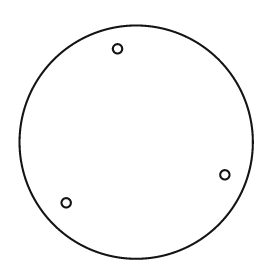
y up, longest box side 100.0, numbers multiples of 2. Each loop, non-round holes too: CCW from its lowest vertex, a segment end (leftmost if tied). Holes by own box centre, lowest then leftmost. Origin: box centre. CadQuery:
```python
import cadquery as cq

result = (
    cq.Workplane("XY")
    .moveTo(0.0, 0.0)
    .circle(50.0)
    .moveTo(-30.0, -26.0)
    .circle(2.0)
    .moveTo(38.0, -14.0)
    .circle(2.0)
    .moveTo(-8.0, 40.0)
    .circle(2.0)
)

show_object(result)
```